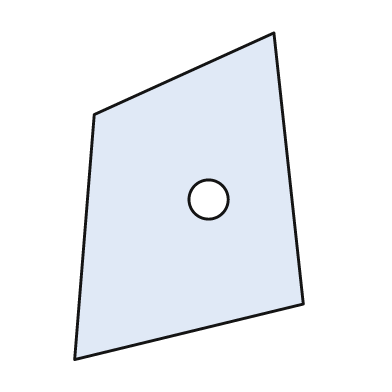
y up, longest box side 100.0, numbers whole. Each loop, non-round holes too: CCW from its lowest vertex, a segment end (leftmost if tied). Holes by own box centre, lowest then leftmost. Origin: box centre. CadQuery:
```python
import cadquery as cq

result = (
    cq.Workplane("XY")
    .moveTo(-35.0, -50.0)
    .lineTo(35.0, -33.0)
    .lineTo(26.0, 50.0)
    .lineTo(-29.0, 25.0)
    .close()
    .moveTo(6.0, -1.0)
    .circle(6.0)
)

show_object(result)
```